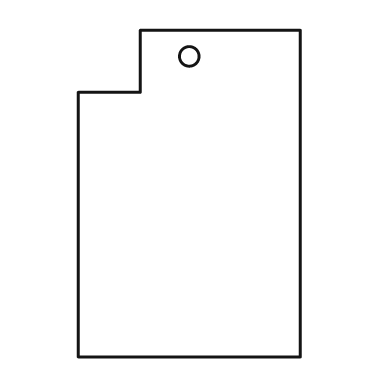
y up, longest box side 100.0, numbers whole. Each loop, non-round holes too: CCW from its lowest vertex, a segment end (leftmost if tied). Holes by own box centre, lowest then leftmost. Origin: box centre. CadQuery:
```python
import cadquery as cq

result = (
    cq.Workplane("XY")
    .moveTo(-34.0, -50.0)
    .lineTo(34.0, -50.0)
    .lineTo(34.0, 50.0)
    .lineTo(-15.0, 50.0)
    .lineTo(-15.0, 31.0)
    .lineTo(-34.0, 31.0)
    .close()
    .moveTo(0.0, 42.0)
    .circle(3.0)
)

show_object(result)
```